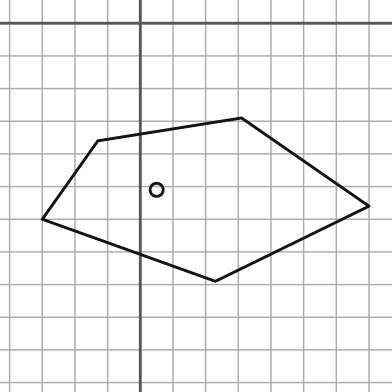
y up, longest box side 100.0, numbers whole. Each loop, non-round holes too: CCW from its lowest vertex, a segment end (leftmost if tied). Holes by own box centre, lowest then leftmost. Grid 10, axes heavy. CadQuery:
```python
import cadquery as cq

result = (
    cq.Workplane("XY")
    .moveTo(23.0, -79.0)
    .lineTo(70.0, -56.0)
    .lineTo(31.0, -29.0)
    .lineTo(-13.0, -36.0)
    .lineTo(-30.0, -60.0)
    .close()
    .moveTo(5.0, -51.0)
    .circle(2.0)
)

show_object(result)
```